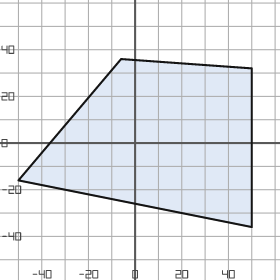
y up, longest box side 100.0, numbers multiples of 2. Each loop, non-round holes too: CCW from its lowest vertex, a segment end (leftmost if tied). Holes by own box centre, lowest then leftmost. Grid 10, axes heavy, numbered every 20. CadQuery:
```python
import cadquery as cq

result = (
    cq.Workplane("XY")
    .moveTo(50.0, -36.0)
    .lineTo(50.0, 32.0)
    .lineTo(-6.0, 36.0)
    .lineTo(-50.0, -16.0)
    .close()
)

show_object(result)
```